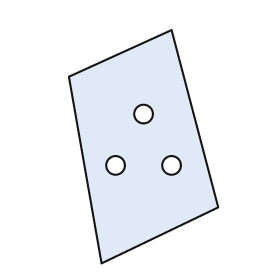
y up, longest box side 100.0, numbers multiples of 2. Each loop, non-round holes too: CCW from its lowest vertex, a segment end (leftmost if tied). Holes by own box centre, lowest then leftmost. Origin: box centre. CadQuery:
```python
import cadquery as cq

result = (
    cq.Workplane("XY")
    .moveTo(-18.0, -50.0)
    .lineTo(32.0, -26.0)
    .lineTo(12.0, 50.0)
    .lineTo(-32.0, 30.0)
    .close()
    .moveTo(-12.0, -8.0)
    .circle(4.0)
    .moveTo(12.0, -8.0)
    .circle(4.0)
    .moveTo(0.0, 14.0)
    .circle(4.0)
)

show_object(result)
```